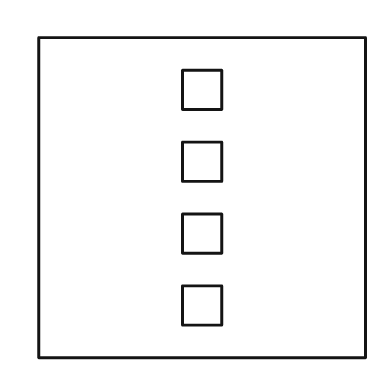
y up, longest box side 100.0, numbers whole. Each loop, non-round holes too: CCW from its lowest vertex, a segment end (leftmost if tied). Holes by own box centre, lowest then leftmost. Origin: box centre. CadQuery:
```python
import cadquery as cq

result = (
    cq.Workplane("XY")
    .moveTo(-50.0, -49.0)
    .lineTo(50.0, -49.0)
    .lineTo(50.0, 49.0)
    .lineTo(-50.0, 49.0)
    .close()
    .moveTo(-6.0, -39.0)
    .lineTo(6.0, -39.0)
    .lineTo(6.0, -27.0)
    .lineTo(-6.0, -27.0)
    .close()
    .moveTo(-6.0, -17.0)
    .lineTo(6.0, -17.0)
    .lineTo(6.0, -5.0)
    .lineTo(-6.0, -5.0)
    .close()
    .moveTo(-6.0, 5.0)
    .lineTo(6.0, 5.0)
    .lineTo(6.0, 17.0)
    .lineTo(-6.0, 17.0)
    .close()
    .moveTo(-6.0, 27.0)
    .lineTo(6.0, 27.0)
    .lineTo(6.0, 39.0)
    .lineTo(-6.0, 39.0)
    .close()
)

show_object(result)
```